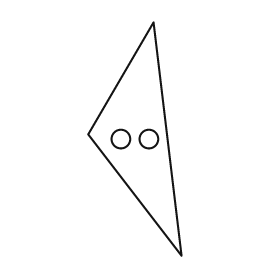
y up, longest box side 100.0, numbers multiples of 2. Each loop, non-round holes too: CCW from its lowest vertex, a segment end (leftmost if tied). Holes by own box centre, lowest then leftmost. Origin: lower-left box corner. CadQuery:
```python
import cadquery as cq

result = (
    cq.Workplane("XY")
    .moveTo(40.0, 0.0)
    .lineTo(28.0, 100.0)
    .lineTo(0.0, 52.0)
    .close()
    .moveTo(14.0, 50.0)
    .circle(4.0)
    .moveTo(26.0, 50.0)
    .circle(4.0)
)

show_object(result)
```